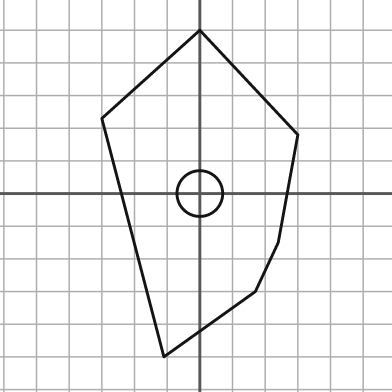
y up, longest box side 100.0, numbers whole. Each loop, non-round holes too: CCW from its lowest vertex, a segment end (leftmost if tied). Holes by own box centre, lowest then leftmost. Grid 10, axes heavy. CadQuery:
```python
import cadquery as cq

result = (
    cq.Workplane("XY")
    .moveTo(-11.0, -50.0)
    .lineTo(17.0, -30.0)
    .lineTo(24.0, -15.0)
    .lineTo(30.0, 18.0)
    .lineTo(0.0, 50.0)
    .lineTo(-30.0, 23.0)
    .close()
    .moveTo(0.0, 0.0)
    .circle(7.0)
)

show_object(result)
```